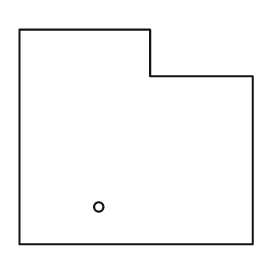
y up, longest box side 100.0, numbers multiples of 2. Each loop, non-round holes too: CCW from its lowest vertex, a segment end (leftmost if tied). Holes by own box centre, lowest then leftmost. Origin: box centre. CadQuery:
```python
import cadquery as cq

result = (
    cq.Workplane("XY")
    .moveTo(-50.0, -46.0)
    .lineTo(50.0, -46.0)
    .lineTo(50.0, 26.0)
    .lineTo(6.0, 26.0)
    .lineTo(6.0, 46.0)
    .lineTo(-50.0, 46.0)
    .close()
    .moveTo(-16.0, -30.0)
    .circle(2.0)
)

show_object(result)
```